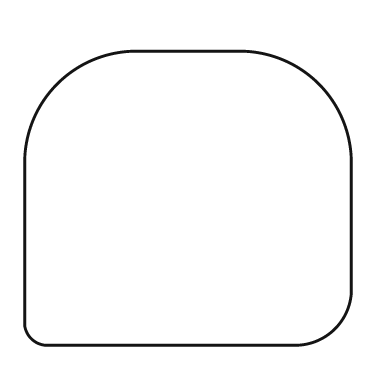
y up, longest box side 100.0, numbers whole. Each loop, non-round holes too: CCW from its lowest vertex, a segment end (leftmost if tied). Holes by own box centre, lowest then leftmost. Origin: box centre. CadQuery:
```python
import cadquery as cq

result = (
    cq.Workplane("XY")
    .moveTo(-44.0, -45.0)
    .lineTo(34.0, -45.0)
    .threePointArc((45.0, -40.0), (50.0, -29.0))
    .lineTo(50.0, 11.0)
    .threePointArc((40.0, 35.0), (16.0, 45.0))
    .lineTo(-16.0, 45.0)
    .threePointArc((-40.0, 35.0), (-50.0, 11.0))
    .lineTo(-50.0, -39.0)
    .threePointArc((-48.0, -43.0), (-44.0, -45.0))
    .close()
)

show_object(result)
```